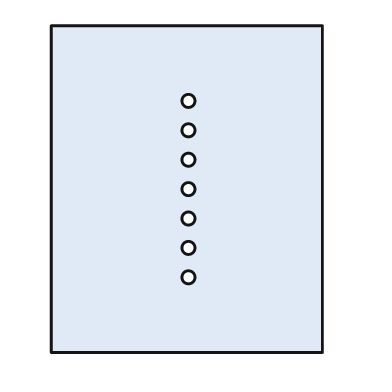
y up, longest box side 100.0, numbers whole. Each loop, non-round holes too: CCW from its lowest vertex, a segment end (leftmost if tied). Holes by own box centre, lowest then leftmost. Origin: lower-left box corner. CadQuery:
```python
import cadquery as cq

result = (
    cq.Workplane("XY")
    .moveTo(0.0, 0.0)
    .lineTo(83.0, 0.0)
    .lineTo(83.0, 100.0)
    .lineTo(0.0, 100.0)
    .close()
    .moveTo(42.0, 23.0)
    .circle(2.0)
    .moveTo(42.0, 32.0)
    .circle(2.0)
    .moveTo(42.0, 41.0)
    .circle(2.0)
    .moveTo(42.0, 50.0)
    .circle(2.0)
    .moveTo(42.0, 59.0)
    .circle(2.0)
    .moveTo(42.0, 68.0)
    .circle(2.0)
    .moveTo(42.0, 77.0)
    .circle(2.0)
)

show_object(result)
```